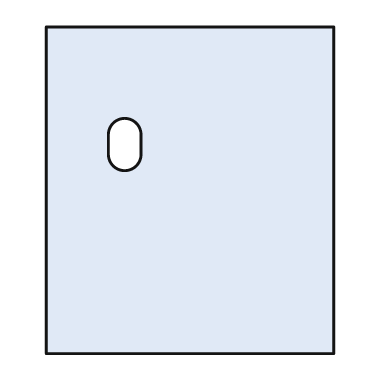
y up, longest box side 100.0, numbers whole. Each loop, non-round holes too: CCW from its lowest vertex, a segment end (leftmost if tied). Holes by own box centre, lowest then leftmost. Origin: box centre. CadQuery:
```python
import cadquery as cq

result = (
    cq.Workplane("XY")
    .moveTo(-44.0, -50.0)
    .lineTo(44.0, -50.0)
    .lineTo(44.0, 50.0)
    .lineTo(-44.0, 50.0)
    .close()
    .moveTo(-25.0, 11.0)
    .threePointArc((-20.0, 6.0), (-15.0, 11.0))
    .lineTo(-15.0, 17.0)
    .threePointArc((-20.0, 22.0), (-25.0, 17.0))
    .close()
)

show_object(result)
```